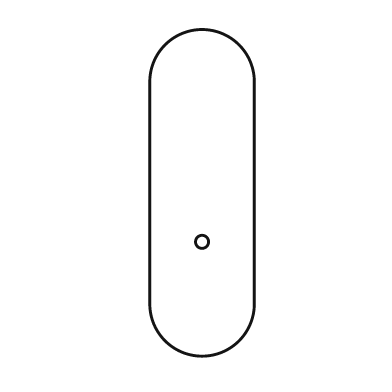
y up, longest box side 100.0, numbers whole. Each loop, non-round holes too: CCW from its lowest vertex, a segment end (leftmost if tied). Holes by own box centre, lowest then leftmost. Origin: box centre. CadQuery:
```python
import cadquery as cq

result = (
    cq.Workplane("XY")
    .moveTo(-16.0, -34.0)
    .threePointArc((0.0, -50.0), (16.0, -34.0))
    .lineTo(16.0, 34.0)
    .threePointArc((0.0, 50.0), (-16.0, 34.0))
    .close()
    .moveTo(0.0, -15.0)
    .circle(2.0)
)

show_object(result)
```